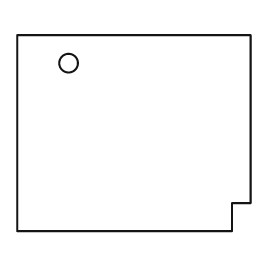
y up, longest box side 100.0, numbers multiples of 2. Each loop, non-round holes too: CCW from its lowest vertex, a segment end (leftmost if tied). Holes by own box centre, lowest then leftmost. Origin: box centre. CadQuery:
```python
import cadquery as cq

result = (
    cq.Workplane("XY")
    .moveTo(-50.0, -42.0)
    .lineTo(42.0, -42.0)
    .lineTo(42.0, -30.0)
    .lineTo(50.0, -30.0)
    .lineTo(50.0, 42.0)
    .lineTo(-50.0, 42.0)
    .close()
    .moveTo(-28.0, 30.0)
    .circle(4.0)
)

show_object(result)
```